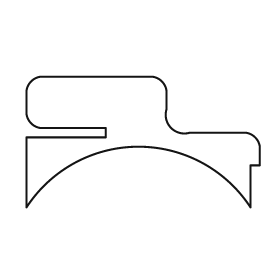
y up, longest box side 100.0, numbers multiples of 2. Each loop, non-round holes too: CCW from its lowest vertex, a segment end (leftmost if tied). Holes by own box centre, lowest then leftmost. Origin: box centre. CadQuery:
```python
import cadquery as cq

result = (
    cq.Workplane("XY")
    .moveTo(-50.0, -28.0)
    .threePointArc((-2.0, -2.0), (46.0, -28.0))
    .lineTo(46.0, -10.0)
    .lineTo(50.0, -10.0)
    .lineTo(50.0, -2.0)
    .threePointArc((48.0, 2.0), (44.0, 4.0))
    .lineTo(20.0, 4.0)
    .threePointArc((12.0, 6.0), (10.0, 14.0))
    .lineTo(10.0, 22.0)
    .threePointArc((8.0, 26.0), (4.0, 28.0))
    .lineTo(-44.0, 28.0)
    .threePointArc((-48.0, 26.0), (-50.0, 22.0))
    .lineTo(-50.0, 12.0)
    .threePointArc((-48.0, 8.0), (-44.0, 6.0))
    .lineTo(-16.0, 6.0)
    .lineTo(-16.0, 2.0)
    .lineTo(-50.0, 2.0)
    .close()
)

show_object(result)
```